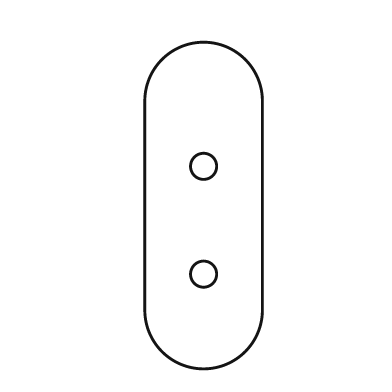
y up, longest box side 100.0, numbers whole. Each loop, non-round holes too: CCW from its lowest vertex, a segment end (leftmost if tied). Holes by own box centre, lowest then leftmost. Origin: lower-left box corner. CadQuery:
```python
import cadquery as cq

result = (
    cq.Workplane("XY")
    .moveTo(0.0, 18.0)
    .threePointArc((18.0, 0.0), (36.0, 18.0))
    .lineTo(36.0, 82.0)
    .threePointArc((18.0, 100.0), (0.0, 82.0))
    .close()
    .moveTo(18.0, 29.0)
    .circle(4.0)
    .moveTo(18.0, 62.0)
    .circle(4.0)
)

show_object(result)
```